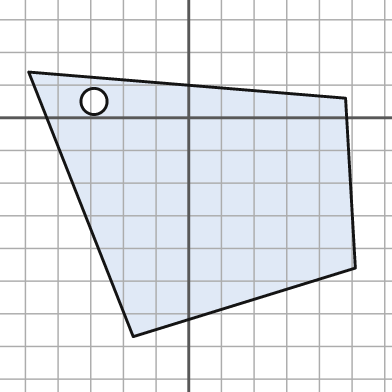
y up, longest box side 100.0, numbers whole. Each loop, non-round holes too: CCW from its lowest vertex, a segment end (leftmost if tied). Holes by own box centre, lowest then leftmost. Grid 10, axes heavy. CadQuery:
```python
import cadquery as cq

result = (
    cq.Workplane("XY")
    .moveTo(-17.0, -67.0)
    .lineTo(51.0, -46.0)
    .lineTo(48.0, 6.0)
    .lineTo(-49.0, 14.0)
    .close()
    .moveTo(-29.0, 5.0)
    .circle(4.0)
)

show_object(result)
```